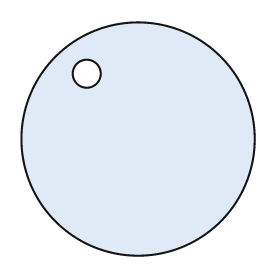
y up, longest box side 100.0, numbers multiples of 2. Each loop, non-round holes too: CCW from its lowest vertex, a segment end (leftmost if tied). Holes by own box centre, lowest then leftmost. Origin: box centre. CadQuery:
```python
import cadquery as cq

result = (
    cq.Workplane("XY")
    .moveTo(0.0, 0.0)
    .circle(50.0)
    .moveTo(-22.0, 28.0)
    .circle(6.0)
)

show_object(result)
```